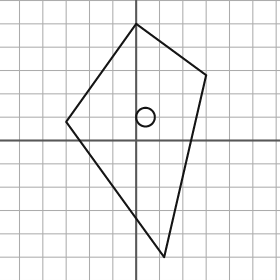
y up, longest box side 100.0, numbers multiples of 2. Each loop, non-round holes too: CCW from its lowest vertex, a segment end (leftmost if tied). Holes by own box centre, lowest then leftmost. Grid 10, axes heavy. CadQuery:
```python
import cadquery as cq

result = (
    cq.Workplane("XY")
    .moveTo(12.0, -50.0)
    .lineTo(30.0, 28.0)
    .lineTo(0.0, 50.0)
    .lineTo(-30.0, 8.0)
    .close()
    .moveTo(4.0, 10.0)
    .circle(4.0)
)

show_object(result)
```